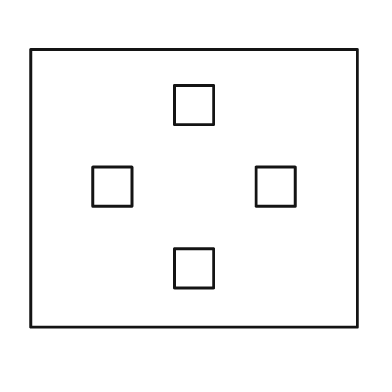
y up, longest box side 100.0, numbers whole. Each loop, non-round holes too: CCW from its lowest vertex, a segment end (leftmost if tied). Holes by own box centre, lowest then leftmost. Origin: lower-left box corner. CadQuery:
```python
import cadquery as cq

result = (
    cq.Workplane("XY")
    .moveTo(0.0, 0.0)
    .lineTo(100.0, 0.0)
    .lineTo(100.0, 85.0)
    .lineTo(0.0, 85.0)
    .close()
    .moveTo(44.0, 12.0)
    .lineTo(56.0, 12.0)
    .lineTo(56.0, 24.0)
    .lineTo(44.0, 24.0)
    .close()
    .moveTo(19.0, 37.0)
    .lineTo(31.0, 37.0)
    .lineTo(31.0, 49.0)
    .lineTo(19.0, 49.0)
    .close()
    .moveTo(69.0, 37.0)
    .lineTo(81.0, 37.0)
    .lineTo(81.0, 49.0)
    .lineTo(69.0, 49.0)
    .close()
    .moveTo(44.0, 62.0)
    .lineTo(56.0, 62.0)
    .lineTo(56.0, 74.0)
    .lineTo(44.0, 74.0)
    .close()
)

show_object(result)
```